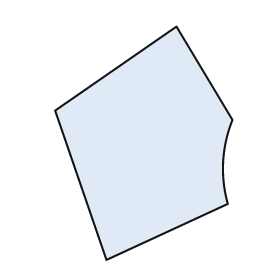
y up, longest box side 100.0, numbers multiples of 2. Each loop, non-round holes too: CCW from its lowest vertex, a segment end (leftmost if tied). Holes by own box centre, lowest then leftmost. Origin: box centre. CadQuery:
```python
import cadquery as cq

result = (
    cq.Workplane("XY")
    .moveTo(-16.0, -50.0)
    .lineTo(36.0, -26.0)
    .threePointArc((34.0, -8.0), (38.0, 10.0))
    .lineTo(14.0, 50.0)
    .lineTo(-38.0, 14.0)
    .close()
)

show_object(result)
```